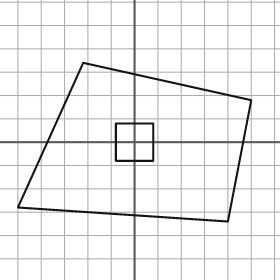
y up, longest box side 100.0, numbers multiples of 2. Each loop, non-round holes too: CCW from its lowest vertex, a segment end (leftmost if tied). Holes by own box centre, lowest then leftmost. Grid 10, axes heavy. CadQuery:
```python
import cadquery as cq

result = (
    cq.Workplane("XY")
    .moveTo(40.0, -34.0)
    .lineTo(50.0, 18.0)
    .lineTo(-22.0, 34.0)
    .lineTo(-50.0, -28.0)
    .close()
    .moveTo(-8.0, -8.0)
    .lineTo(8.0, -8.0)
    .lineTo(8.0, 8.0)
    .lineTo(-8.0, 8.0)
    .close()
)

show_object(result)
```